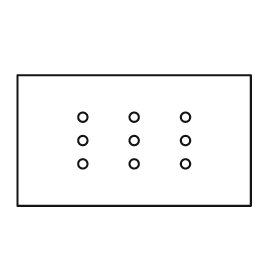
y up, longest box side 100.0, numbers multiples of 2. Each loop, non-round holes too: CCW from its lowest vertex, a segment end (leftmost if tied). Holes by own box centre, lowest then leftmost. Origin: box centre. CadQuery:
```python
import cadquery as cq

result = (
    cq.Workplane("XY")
    .moveTo(-50.0, -28.0)
    .lineTo(50.0, -28.0)
    .lineTo(50.0, 28.0)
    .lineTo(-50.0, 28.0)
    .close()
    .moveTo(-22.0, -10.0)
    .circle(2.0)
    .moveTo(0.0, -10.0)
    .circle(2.0)
    .moveTo(22.0, -10.0)
    .circle(2.0)
    .moveTo(-22.0, 0.0)
    .circle(2.0)
    .moveTo(0.0, 0.0)
    .circle(2.0)
    .moveTo(22.0, 0.0)
    .circle(2.0)
    .moveTo(-22.0, 10.0)
    .circle(2.0)
    .moveTo(0.0, 10.0)
    .circle(2.0)
    .moveTo(22.0, 10.0)
    .circle(2.0)
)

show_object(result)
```